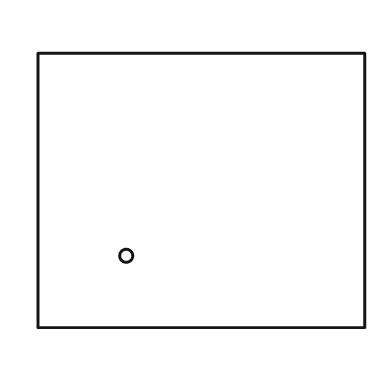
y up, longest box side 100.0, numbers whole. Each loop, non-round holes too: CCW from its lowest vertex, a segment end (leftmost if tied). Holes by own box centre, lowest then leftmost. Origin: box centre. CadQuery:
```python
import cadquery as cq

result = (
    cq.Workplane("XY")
    .moveTo(-50.0, -42.0)
    .lineTo(50.0, -42.0)
    .lineTo(50.0, 42.0)
    .lineTo(-50.0, 42.0)
    .close()
    .moveTo(-23.0, -20.0)
    .circle(2.0)
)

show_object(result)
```